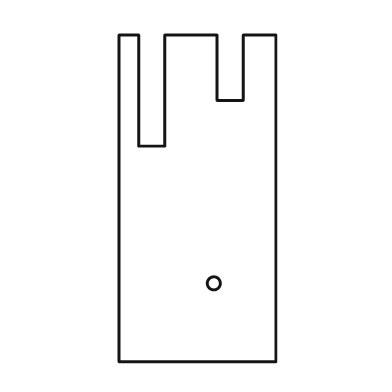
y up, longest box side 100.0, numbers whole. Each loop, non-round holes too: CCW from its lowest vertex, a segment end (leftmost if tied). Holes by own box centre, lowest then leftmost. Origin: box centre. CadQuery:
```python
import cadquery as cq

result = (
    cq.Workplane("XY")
    .moveTo(-24.0, -50.0)
    .lineTo(24.0, -50.0)
    .lineTo(24.0, 50.0)
    .lineTo(14.0, 50.0)
    .lineTo(14.0, 30.0)
    .lineTo(6.0, 30.0)
    .lineTo(6.0, 50.0)
    .lineTo(-10.0, 50.0)
    .lineTo(-10.0, 16.0)
    .lineTo(-18.0, 16.0)
    .lineTo(-18.0, 50.0)
    .lineTo(-24.0, 50.0)
    .close()
    .moveTo(5.0, -26.0)
    .circle(2.0)
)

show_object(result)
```